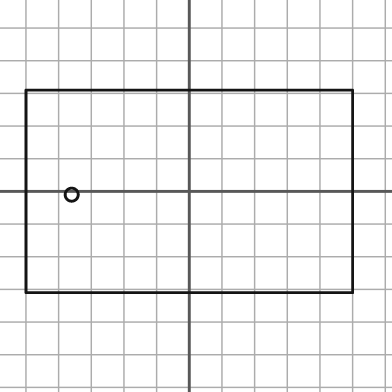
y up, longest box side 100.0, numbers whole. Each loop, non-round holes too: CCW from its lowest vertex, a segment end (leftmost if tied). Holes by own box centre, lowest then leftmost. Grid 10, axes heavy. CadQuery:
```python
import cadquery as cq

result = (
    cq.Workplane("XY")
    .moveTo(-50.0, -31.0)
    .lineTo(50.0, -31.0)
    .lineTo(50.0, 31.0)
    .lineTo(-50.0, 31.0)
    .close()
    .moveTo(-36.0, -1.0)
    .circle(2.0)
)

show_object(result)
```